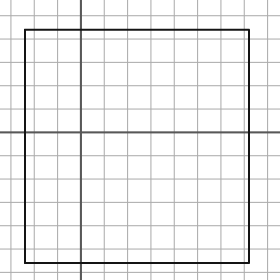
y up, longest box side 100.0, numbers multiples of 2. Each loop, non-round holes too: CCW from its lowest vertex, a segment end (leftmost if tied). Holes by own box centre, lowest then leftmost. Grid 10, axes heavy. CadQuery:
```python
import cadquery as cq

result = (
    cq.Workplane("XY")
    .moveTo(-24.0, -56.0)
    .lineTo(72.0, -56.0)
    .lineTo(72.0, 44.0)
    .lineTo(-24.0, 44.0)
    .close()
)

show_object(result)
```